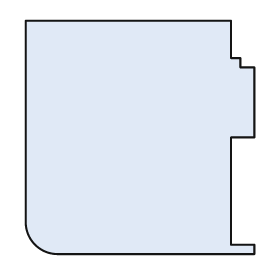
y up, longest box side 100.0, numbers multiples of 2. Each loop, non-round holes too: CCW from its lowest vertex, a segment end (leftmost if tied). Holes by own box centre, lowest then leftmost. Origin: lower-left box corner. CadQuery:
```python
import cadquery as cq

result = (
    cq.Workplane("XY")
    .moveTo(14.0, 0.0)
    .lineTo(98.0, 0.0)
    .lineTo(98.0, 4.0)
    .lineTo(88.0, 4.0)
    .lineTo(88.0, 50.0)
    .lineTo(98.0, 50.0)
    .lineTo(98.0, 80.0)
    .lineTo(92.0, 80.0)
    .lineTo(92.0, 84.0)
    .lineTo(88.0, 84.0)
    .lineTo(88.0, 100.0)
    .lineTo(0.0, 100.0)
    .lineTo(0.0, 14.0)
    .threePointArc((4.0, 4.0), (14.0, 0.0))
    .close()
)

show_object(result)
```